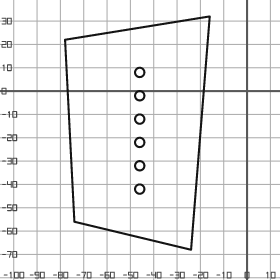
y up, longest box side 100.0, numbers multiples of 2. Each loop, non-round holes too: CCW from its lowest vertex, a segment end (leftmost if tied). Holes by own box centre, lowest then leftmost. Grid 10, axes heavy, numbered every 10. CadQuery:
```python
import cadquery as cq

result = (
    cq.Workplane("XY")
    .moveTo(-24.0, -68.0)
    .lineTo(-16.0, 32.0)
    .lineTo(-78.0, 22.0)
    .lineTo(-74.0, -56.0)
    .close()
    .moveTo(-46.0, -42.0)
    .circle(2.0)
    .moveTo(-46.0, -32.0)
    .circle(2.0)
    .moveTo(-46.0, -22.0)
    .circle(2.0)
    .moveTo(-46.0, -12.0)
    .circle(2.0)
    .moveTo(-46.0, -2.0)
    .circle(2.0)
    .moveTo(-46.0, 8.0)
    .circle(2.0)
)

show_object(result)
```